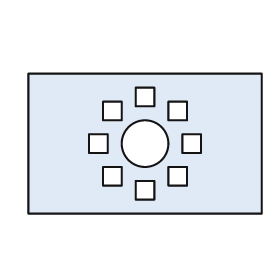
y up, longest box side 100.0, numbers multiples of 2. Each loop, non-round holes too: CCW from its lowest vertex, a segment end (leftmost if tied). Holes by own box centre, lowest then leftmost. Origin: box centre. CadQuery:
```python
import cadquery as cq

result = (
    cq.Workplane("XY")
    .moveTo(-50.0, -30.0)
    .lineTo(50.0, -30.0)
    .lineTo(50.0, 30.0)
    .lineTo(-50.0, 30.0)
    .close()
    .moveTo(-4.0, -24.0)
    .lineTo(4.0, -24.0)
    .lineTo(4.0, -16.0)
    .lineTo(-4.0, -16.0)
    .close()
    .moveTo(-18.0, -18.0)
    .lineTo(-10.0, -18.0)
    .lineTo(-10.0, -10.0)
    .lineTo(-18.0, -10.0)
    .close()
    .moveTo(10.0, -18.0)
    .lineTo(18.0, -18.0)
    .lineTo(18.0, -10.0)
    .lineTo(10.0, -10.0)
    .close()
    .moveTo(-24.0, -4.0)
    .lineTo(-16.0, -4.0)
    .lineTo(-16.0, 4.0)
    .lineTo(-24.0, 4.0)
    .close()
    .moveTo(0.0, 0.0)
    .circle(10.0)
    .moveTo(16.0, -4.0)
    .lineTo(24.0, -4.0)
    .lineTo(24.0, 4.0)
    .lineTo(16.0, 4.0)
    .close()
    .moveTo(-18.0, 10.0)
    .lineTo(-10.0, 10.0)
    .lineTo(-10.0, 18.0)
    .lineTo(-18.0, 18.0)
    .close()
    .moveTo(10.0, 10.0)
    .lineTo(18.0, 10.0)
    .lineTo(18.0, 18.0)
    .lineTo(10.0, 18.0)
    .close()
    .moveTo(-4.0, 16.0)
    .lineTo(4.0, 16.0)
    .lineTo(4.0, 24.0)
    .lineTo(-4.0, 24.0)
    .close()
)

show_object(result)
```